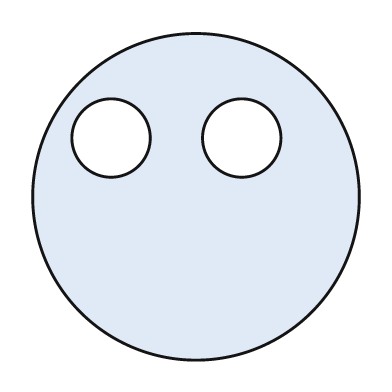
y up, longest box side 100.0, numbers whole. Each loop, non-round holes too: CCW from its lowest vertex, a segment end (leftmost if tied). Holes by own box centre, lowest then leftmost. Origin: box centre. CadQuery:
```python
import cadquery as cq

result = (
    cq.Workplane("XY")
    .moveTo(0.0, 0.0)
    .circle(50.0)
    .moveTo(-26.0, 18.0)
    .circle(12.0)
    .moveTo(14.0, 18.0)
    .circle(12.0)
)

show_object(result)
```